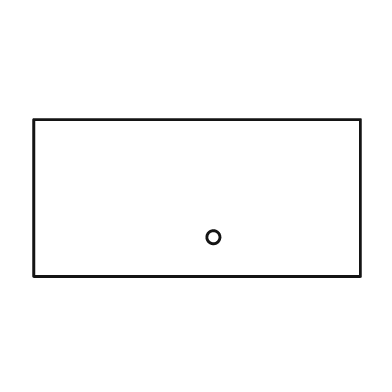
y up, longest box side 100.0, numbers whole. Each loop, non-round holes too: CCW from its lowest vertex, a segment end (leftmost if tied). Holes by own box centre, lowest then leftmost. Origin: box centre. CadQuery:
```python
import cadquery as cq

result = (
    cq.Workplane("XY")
    .moveTo(-50.0, -24.0)
    .lineTo(50.0, -24.0)
    .lineTo(50.0, 24.0)
    .lineTo(-50.0, 24.0)
    .close()
    .moveTo(5.0, -12.0)
    .circle(2.0)
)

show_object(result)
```